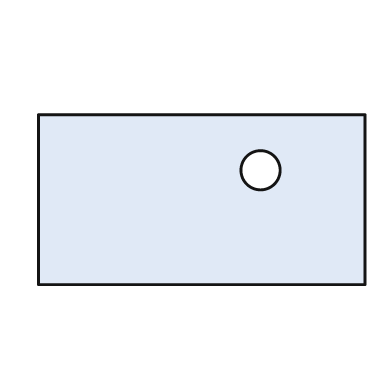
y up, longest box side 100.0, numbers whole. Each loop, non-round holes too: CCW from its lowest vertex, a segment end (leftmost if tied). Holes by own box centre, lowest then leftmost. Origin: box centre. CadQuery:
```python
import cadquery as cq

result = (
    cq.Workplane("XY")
    .moveTo(-50.0, -26.0)
    .lineTo(50.0, -26.0)
    .lineTo(50.0, 26.0)
    .lineTo(-50.0, 26.0)
    .close()
    .moveTo(18.0, 9.0)
    .circle(6.0)
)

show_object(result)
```